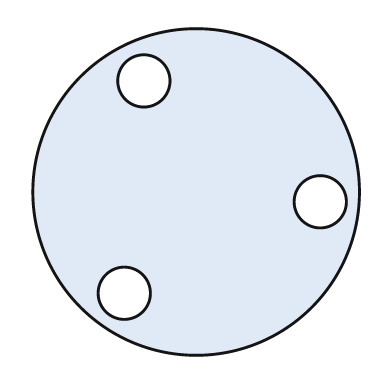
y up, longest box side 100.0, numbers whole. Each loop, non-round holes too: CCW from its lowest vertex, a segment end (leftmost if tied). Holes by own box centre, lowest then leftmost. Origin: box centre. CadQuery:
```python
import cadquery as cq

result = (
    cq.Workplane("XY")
    .moveTo(0.0, 0.0)
    .circle(50.0)
    .moveTo(-22.0, -31.0)
    .circle(8.0)
    .moveTo(38.0, -3.0)
    .circle(8.0)
    .moveTo(-16.0, 34.0)
    .circle(8.0)
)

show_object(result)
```